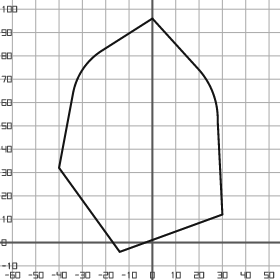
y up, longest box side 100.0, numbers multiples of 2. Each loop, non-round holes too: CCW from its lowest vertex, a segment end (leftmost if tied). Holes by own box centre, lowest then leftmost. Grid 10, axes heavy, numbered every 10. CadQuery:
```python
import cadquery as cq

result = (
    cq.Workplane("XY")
    .moveTo(-14.0, -4.0)
    .lineTo(30.0, 12.0)
    .lineTo(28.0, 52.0)
    .threePointArc((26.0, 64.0), (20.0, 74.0))
    .lineTo(0.0, 96.0)
    .lineTo(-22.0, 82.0)
    .threePointArc((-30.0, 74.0), (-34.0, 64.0))
    .lineTo(-40.0, 32.0)
    .close()
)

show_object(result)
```